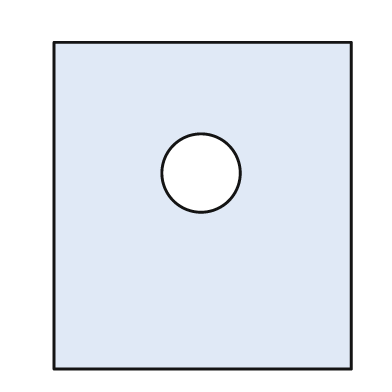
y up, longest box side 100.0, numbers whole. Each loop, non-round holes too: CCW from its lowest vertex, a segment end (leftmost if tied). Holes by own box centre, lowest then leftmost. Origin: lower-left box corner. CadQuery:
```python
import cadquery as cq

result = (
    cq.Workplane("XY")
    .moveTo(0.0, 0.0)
    .lineTo(91.0, 0.0)
    .lineTo(91.0, 100.0)
    .lineTo(0.0, 100.0)
    .close()
    .moveTo(45.0, 60.0)
    .circle(12.0)
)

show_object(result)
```